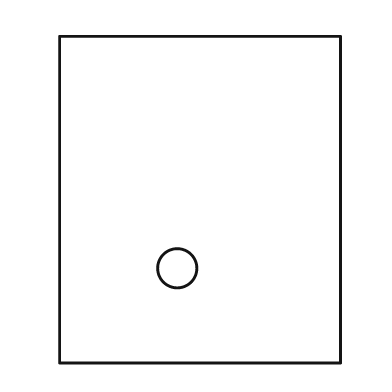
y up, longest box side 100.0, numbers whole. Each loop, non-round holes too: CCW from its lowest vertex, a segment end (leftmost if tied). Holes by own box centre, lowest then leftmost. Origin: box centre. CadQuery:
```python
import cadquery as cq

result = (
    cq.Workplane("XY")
    .moveTo(-43.0, -50.0)
    .lineTo(43.0, -50.0)
    .lineTo(43.0, 50.0)
    .lineTo(-43.0, 50.0)
    .close()
    .moveTo(-7.0, -21.0)
    .circle(6.0)
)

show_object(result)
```